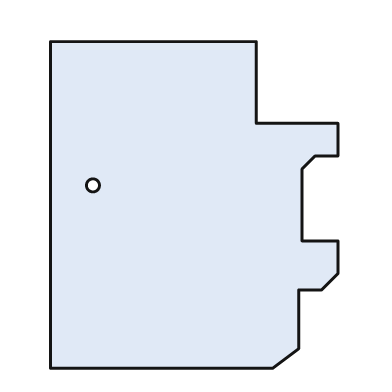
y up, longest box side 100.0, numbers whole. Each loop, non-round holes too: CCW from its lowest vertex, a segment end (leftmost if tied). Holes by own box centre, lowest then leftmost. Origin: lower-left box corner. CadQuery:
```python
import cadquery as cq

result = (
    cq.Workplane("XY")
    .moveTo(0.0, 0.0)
    .lineTo(68.0, 0.0)
    .lineTo(76.0, 6.0)
    .lineTo(76.0, 24.0)
    .lineTo(83.0, 24.0)
    .lineTo(88.0, 29.0)
    .lineTo(88.0, 39.0)
    .lineTo(77.0, 39.0)
    .lineTo(77.0, 61.0)
    .lineTo(81.0, 65.0)
    .lineTo(88.0, 65.0)
    .lineTo(88.0, 75.0)
    .lineTo(63.0, 75.0)
    .lineTo(63.0, 100.0)
    .lineTo(0.0, 100.0)
    .close()
    .moveTo(13.0, 56.0)
    .circle(2.0)
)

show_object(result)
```